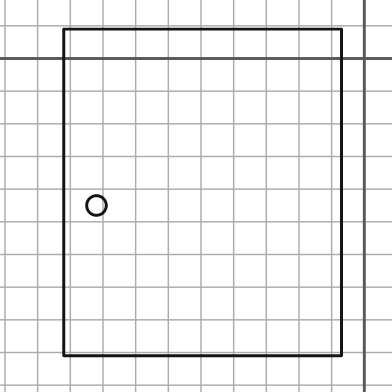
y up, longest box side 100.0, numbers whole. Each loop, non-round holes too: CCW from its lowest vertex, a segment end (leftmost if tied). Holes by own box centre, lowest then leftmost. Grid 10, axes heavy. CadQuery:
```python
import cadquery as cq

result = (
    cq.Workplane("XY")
    .moveTo(-92.0, -91.0)
    .lineTo(-7.0, -91.0)
    .lineTo(-7.0, 9.0)
    .lineTo(-92.0, 9.0)
    .close()
    .moveTo(-82.0, -45.0)
    .circle(3.0)
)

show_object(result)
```